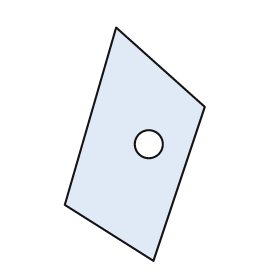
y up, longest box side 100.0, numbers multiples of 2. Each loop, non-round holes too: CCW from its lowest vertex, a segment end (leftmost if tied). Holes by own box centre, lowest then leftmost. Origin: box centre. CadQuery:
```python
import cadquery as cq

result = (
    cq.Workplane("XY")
    .moveTo(8.0, -50.0)
    .lineTo(30.0, 16.0)
    .lineTo(-8.0, 50.0)
    .lineTo(-30.0, -26.0)
    .close()
    .moveTo(6.0, 0.0)
    .circle(6.0)
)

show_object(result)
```